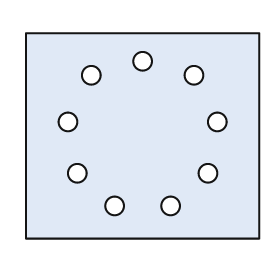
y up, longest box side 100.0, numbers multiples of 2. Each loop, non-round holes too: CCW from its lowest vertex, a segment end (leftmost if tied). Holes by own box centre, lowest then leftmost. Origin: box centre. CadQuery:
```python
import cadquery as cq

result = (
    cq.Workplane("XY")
    .moveTo(-50.0, -44.0)
    .lineTo(50.0, -44.0)
    .lineTo(50.0, 44.0)
    .lineTo(-50.0, 44.0)
    .close()
    .moveTo(-12.0, -30.0)
    .circle(4.0)
    .moveTo(12.0, -30.0)
    .circle(4.0)
    .moveTo(-28.0, -16.0)
    .circle(4.0)
    .moveTo(28.0, -16.0)
    .circle(4.0)
    .moveTo(-32.0, 6.0)
    .circle(4.0)
    .moveTo(32.0, 6.0)
    .circle(4.0)
    .moveTo(-22.0, 26.0)
    .circle(4.0)
    .moveTo(22.0, 26.0)
    .circle(4.0)
    .moveTo(0.0, 32.0)
    .circle(4.0)
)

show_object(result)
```